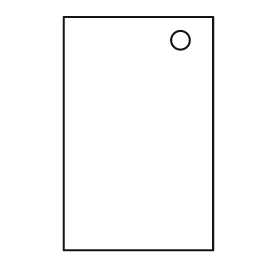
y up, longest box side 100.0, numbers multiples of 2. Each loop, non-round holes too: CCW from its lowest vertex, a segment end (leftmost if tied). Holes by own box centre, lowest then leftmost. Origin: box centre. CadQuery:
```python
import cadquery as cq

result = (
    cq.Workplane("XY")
    .moveTo(-32.0, -50.0)
    .lineTo(32.0, -50.0)
    .lineTo(32.0, 50.0)
    .lineTo(-32.0, 50.0)
    .close()
    .moveTo(18.0, 40.0)
    .circle(4.0)
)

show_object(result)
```